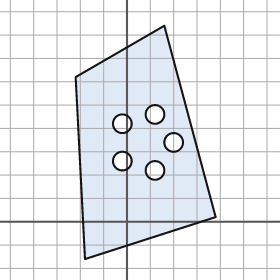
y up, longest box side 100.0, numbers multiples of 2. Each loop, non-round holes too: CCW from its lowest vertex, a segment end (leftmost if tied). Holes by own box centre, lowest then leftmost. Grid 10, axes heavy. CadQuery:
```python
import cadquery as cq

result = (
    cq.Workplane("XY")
    .moveTo(-18.0, -16.0)
    .lineTo(38.0, 2.0)
    .lineTo(16.0, 84.0)
    .lineTo(-22.0, 62.0)
    .close()
    .moveTo(12.0, 22.0)
    .circle(4.0)
    .moveTo(-2.0, 26.0)
    .circle(4.0)
    .moveTo(20.0, 34.0)
    .circle(4.0)
    .moveTo(-2.0, 42.0)
    .circle(4.0)
    .moveTo(12.0, 46.0)
    .circle(4.0)
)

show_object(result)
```